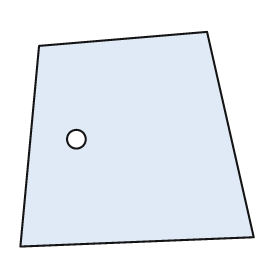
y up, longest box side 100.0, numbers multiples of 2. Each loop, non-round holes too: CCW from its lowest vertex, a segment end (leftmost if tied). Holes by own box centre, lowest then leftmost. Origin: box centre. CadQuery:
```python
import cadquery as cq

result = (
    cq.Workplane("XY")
    .moveTo(-50.0, -46.0)
    .lineTo(50.0, -42.0)
    .lineTo(30.0, 46.0)
    .lineTo(-42.0, 40.0)
    .close()
    .moveTo(-26.0, 0.0)
    .circle(4.0)
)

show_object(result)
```